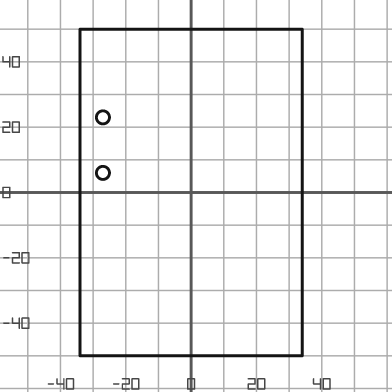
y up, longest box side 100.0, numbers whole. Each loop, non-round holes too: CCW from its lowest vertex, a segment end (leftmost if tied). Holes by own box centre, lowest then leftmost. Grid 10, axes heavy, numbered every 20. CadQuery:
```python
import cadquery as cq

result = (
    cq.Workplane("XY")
    .moveTo(-34.0, -50.0)
    .lineTo(34.0, -50.0)
    .lineTo(34.0, 50.0)
    .lineTo(-34.0, 50.0)
    .close()
    .moveTo(-27.0, 6.0)
    .circle(2.0)
    .moveTo(-27.0, 23.0)
    .circle(2.0)
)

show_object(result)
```